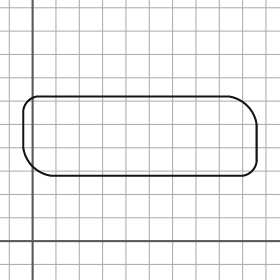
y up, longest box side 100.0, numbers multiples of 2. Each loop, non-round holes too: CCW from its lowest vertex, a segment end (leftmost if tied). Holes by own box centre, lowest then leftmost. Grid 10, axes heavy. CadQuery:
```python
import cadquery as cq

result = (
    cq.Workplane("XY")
    .moveTo(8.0, 28.0)
    .lineTo(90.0, 28.0)
    .threePointArc((94.0, 30.0), (96.0, 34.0))
    .lineTo(96.0, 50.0)
    .threePointArc((92.0, 58.0), (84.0, 62.0))
    .lineTo(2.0, 62.0)
    .threePointArc((-2.0, 60.0), (-4.0, 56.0))
    .lineTo(-4.0, 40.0)
    .threePointArc((0.0, 32.0), (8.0, 28.0))
    .close()
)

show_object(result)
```